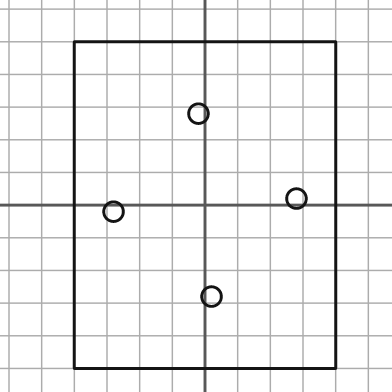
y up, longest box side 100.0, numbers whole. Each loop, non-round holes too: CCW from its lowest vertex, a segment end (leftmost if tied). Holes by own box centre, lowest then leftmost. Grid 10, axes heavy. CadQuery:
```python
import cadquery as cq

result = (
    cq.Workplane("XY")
    .moveTo(-40.0, -50.0)
    .lineTo(40.0, -50.0)
    .lineTo(40.0, 50.0)
    .lineTo(-40.0, 50.0)
    .close()
    .moveTo(2.0, -28.0)
    .circle(3.0)
    .moveTo(-28.0, -2.0)
    .circle(3.0)
    .moveTo(28.0, 2.0)
    .circle(3.0)
    .moveTo(-2.0, 28.0)
    .circle(3.0)
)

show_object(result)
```